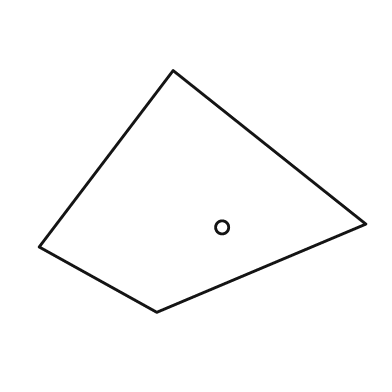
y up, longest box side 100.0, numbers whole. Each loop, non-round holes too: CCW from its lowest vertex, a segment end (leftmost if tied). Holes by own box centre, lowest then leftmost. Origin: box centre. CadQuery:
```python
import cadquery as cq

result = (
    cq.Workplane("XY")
    .moveTo(-14.0, -37.0)
    .lineTo(50.0, -10.0)
    .lineTo(-9.0, 37.0)
    .lineTo(-50.0, -17.0)
    .close()
    .moveTo(6.0, -11.0)
    .circle(2.0)
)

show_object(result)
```